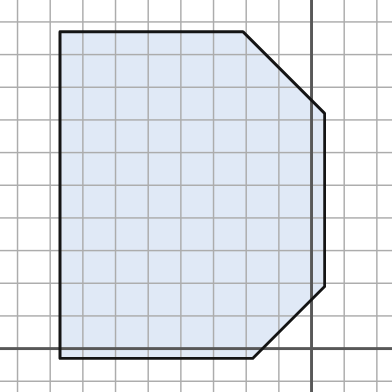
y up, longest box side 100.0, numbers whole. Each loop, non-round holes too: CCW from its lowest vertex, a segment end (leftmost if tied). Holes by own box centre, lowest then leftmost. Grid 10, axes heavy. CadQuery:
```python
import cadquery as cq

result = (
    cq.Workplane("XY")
    .moveTo(-77.0, -3.0)
    .lineTo(-18.0, -3.0)
    .lineTo(4.0, 19.0)
    .lineTo(4.0, 72.0)
    .lineTo(-21.0, 97.0)
    .lineTo(-77.0, 97.0)
    .close()
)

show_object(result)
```